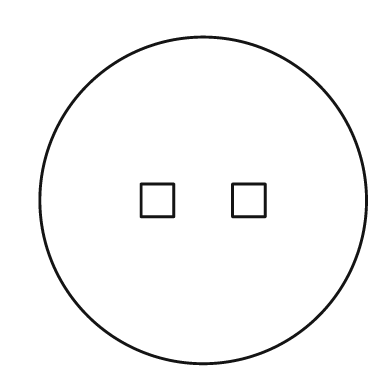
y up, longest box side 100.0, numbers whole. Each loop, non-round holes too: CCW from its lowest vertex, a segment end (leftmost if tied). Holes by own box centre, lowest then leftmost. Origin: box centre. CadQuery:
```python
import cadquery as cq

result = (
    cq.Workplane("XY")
    .moveTo(0.0, 0.0)
    .circle(50.0)
    .moveTo(-19.0, -5.0)
    .lineTo(-9.0, -5.0)
    .lineTo(-9.0, 5.0)
    .lineTo(-19.0, 5.0)
    .close()
    .moveTo(9.0, -5.0)
    .lineTo(19.0, -5.0)
    .lineTo(19.0, 5.0)
    .lineTo(9.0, 5.0)
    .close()
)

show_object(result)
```